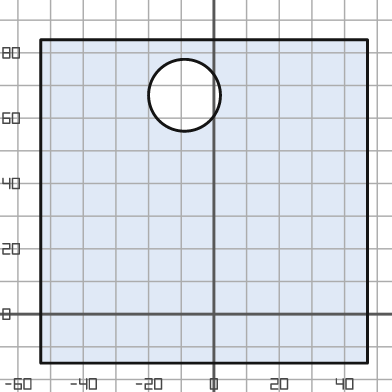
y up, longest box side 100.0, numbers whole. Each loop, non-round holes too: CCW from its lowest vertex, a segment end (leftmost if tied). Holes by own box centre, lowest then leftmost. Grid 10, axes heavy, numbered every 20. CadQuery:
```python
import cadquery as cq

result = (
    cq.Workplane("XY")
    .moveTo(-53.0, -15.0)
    .lineTo(47.0, -15.0)
    .lineTo(47.0, 84.0)
    .lineTo(-53.0, 84.0)
    .close()
    .moveTo(-9.0, 67.0)
    .circle(11.0)
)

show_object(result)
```